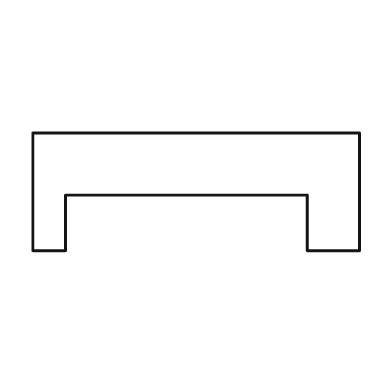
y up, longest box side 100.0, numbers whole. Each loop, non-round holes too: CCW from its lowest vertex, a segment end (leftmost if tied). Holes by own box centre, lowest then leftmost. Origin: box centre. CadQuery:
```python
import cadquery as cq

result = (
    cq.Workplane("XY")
    .moveTo(-50.0, -18.0)
    .lineTo(-40.0, -18.0)
    .lineTo(-40.0, -1.0)
    .lineTo(34.0, -1.0)
    .lineTo(34.0, -18.0)
    .lineTo(50.0, -18.0)
    .lineTo(50.0, 18.0)
    .lineTo(-50.0, 18.0)
    .close()
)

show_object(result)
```